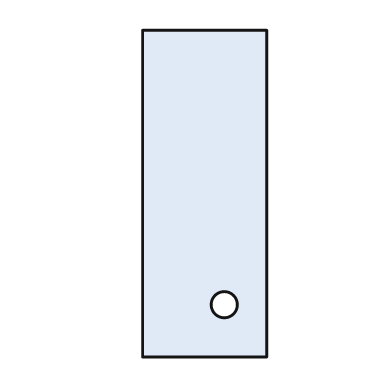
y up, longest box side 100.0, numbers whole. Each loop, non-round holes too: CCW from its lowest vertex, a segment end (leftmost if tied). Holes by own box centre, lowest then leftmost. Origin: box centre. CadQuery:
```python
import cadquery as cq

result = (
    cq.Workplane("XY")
    .moveTo(-19.0, -50.0)
    .lineTo(19.0, -50.0)
    .lineTo(19.0, 50.0)
    .lineTo(-19.0, 50.0)
    .close()
    .moveTo(6.0, -34.0)
    .circle(4.0)
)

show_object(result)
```